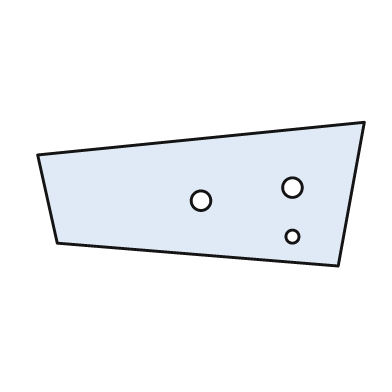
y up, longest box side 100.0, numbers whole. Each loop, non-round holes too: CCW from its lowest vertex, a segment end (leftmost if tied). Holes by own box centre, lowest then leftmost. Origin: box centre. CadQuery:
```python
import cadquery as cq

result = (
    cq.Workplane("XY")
    .moveTo(42.0, -22.0)
    .lineTo(50.0, 22.0)
    .lineTo(-50.0, 12.0)
    .lineTo(-44.0, -15.0)
    .close()
    .moveTo(28.0, -13.0)
    .circle(2.0)
    .moveTo(0.0, -2.0)
    .circle(3.0)
    .moveTo(28.0, 2.0)
    .circle(3.0)
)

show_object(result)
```